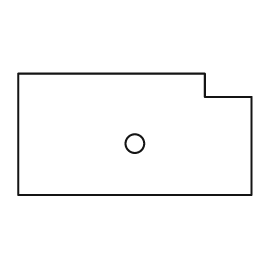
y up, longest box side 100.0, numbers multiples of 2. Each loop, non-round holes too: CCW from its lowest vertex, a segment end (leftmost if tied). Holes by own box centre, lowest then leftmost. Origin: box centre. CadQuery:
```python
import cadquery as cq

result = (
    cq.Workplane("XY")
    .moveTo(-50.0, -26.0)
    .lineTo(50.0, -26.0)
    .lineTo(50.0, 16.0)
    .lineTo(30.0, 16.0)
    .lineTo(30.0, 26.0)
    .lineTo(-50.0, 26.0)
    .close()
    .moveTo(0.0, -4.0)
    .circle(4.0)
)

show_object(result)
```